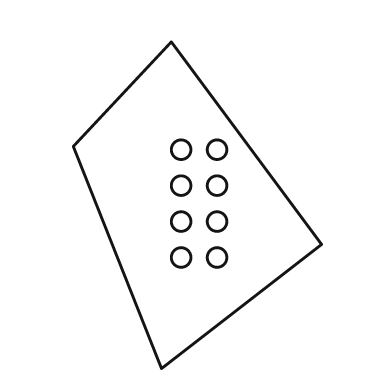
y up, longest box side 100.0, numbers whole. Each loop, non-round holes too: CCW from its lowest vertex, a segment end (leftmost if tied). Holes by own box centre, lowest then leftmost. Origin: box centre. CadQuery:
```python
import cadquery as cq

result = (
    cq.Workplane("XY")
    .moveTo(-11.0, -50.0)
    .lineTo(38.0, -12.0)
    .lineTo(-8.0, 50.0)
    .lineTo(-38.0, 18.0)
    .close()
    .moveTo(-5.0, -16.0)
    .circle(3.0)
    .moveTo(6.0, -16.0)
    .circle(3.0)
    .moveTo(-5.0, -5.0)
    .circle(3.0)
    .moveTo(6.0, -5.0)
    .circle(3.0)
    .moveTo(-5.0, 6.0)
    .circle(3.0)
    .moveTo(6.0, 6.0)
    .circle(3.0)
    .moveTo(-5.0, 17.0)
    .circle(3.0)
    .moveTo(6.0, 17.0)
    .circle(3.0)
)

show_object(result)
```